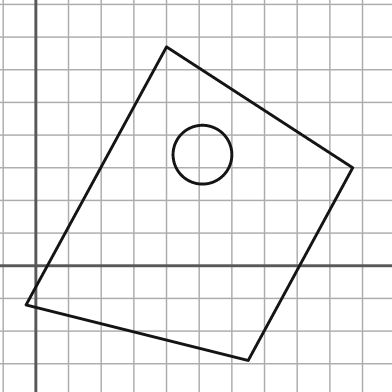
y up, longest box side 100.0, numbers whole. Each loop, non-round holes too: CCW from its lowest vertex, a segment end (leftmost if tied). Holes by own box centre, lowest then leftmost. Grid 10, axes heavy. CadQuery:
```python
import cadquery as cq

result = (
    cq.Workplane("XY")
    .moveTo(65.0, -29.0)
    .lineTo(97.0, 30.0)
    .lineTo(40.0, 67.0)
    .lineTo(-3.0, -12.0)
    .close()
    .moveTo(51.0, 34.0)
    .circle(9.0)
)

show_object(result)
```